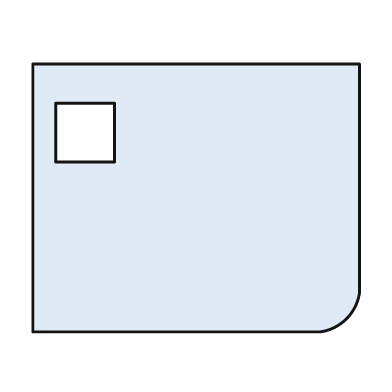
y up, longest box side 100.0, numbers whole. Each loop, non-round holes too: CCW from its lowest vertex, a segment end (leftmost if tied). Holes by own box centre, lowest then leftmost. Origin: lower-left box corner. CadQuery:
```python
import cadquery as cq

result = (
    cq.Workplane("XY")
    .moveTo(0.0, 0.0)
    .lineTo(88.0, 0.0)
    .threePointArc((96.0, 4.0), (100.0, 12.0))
    .lineTo(100.0, 82.0)
    .lineTo(0.0, 82.0)
    .close()
    .moveTo(7.0, 52.0)
    .lineTo(25.0, 52.0)
    .lineTo(25.0, 70.0)
    .lineTo(7.0, 70.0)
    .close()
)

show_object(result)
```